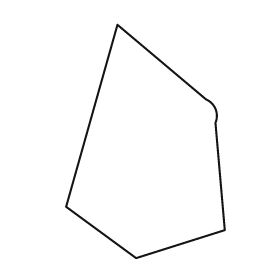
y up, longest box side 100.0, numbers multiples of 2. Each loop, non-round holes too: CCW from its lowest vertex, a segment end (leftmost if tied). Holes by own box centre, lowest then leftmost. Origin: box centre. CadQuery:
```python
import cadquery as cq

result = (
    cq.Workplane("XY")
    .moveTo(-4.0, -50.0)
    .lineTo(34.0, -38.0)
    .lineTo(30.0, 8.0)
    .threePointArc((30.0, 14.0), (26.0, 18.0))
    .lineTo(-12.0, 50.0)
    .lineTo(-34.0, -28.0)
    .close()
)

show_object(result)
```